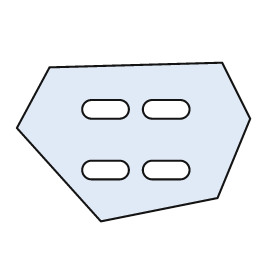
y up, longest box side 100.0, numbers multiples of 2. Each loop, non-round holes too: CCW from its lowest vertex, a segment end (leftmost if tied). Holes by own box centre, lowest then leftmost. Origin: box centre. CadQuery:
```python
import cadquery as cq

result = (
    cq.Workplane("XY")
    .moveTo(-14.0, -34.0)
    .lineTo(36.0, -24.0)
    .lineTo(50.0, 10.0)
    .lineTo(38.0, 34.0)
    .lineTo(-36.0, 32.0)
    .lineTo(-50.0, 6.0)
    .close()
    .moveTo(-18.0, -16.0)
    .lineTo(-6.0, -16.0)
    .threePointArc((-2.0, -12.0), (-6.0, -8.0))
    .lineTo(-18.0, -8.0)
    .threePointArc((-22.0, -12.0), (-18.0, -16.0))
    .close()
    .moveTo(8.0, -16.0)
    .lineTo(20.0, -16.0)
    .threePointArc((24.0, -12.0), (20.0, -8.0))
    .lineTo(8.0, -8.0)
    .threePointArc((4.0, -12.0), (8.0, -16.0))
    .close()
    .moveTo(-18.0, 10.0)
    .lineTo(-6.0, 10.0)
    .threePointArc((-2.0, 14.0), (-6.0, 18.0))
    .lineTo(-18.0, 18.0)
    .threePointArc((-22.0, 14.0), (-18.0, 10.0))
    .close()
    .moveTo(8.0, 10.0)
    .lineTo(20.0, 10.0)
    .threePointArc((24.0, 14.0), (20.0, 18.0))
    .lineTo(8.0, 18.0)
    .threePointArc((4.0, 14.0), (8.0, 10.0))
    .close()
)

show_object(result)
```